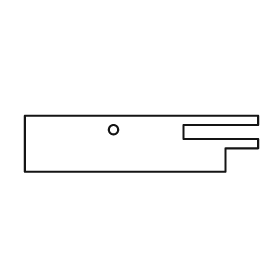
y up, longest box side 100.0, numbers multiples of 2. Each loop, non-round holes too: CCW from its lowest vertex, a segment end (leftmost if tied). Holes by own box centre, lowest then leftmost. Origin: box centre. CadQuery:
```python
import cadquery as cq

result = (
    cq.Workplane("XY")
    .moveTo(-50.0, -12.0)
    .lineTo(36.0, -12.0)
    .lineTo(36.0, -2.0)
    .lineTo(50.0, -2.0)
    .lineTo(50.0, 2.0)
    .lineTo(18.0, 2.0)
    .lineTo(18.0, 8.0)
    .lineTo(50.0, 8.0)
    .lineTo(50.0, 12.0)
    .lineTo(-50.0, 12.0)
    .close()
    .moveTo(-12.0, 6.0)
    .circle(2.0)
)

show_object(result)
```